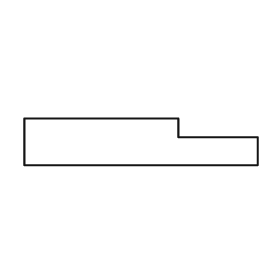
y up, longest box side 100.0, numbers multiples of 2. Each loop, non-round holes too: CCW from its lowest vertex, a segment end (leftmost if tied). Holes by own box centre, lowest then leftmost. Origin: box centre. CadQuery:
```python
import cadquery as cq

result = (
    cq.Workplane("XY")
    .moveTo(-50.0, -10.0)
    .lineTo(50.0, -10.0)
    .lineTo(50.0, 2.0)
    .lineTo(16.0, 2.0)
    .lineTo(16.0, 10.0)
    .lineTo(-50.0, 10.0)
    .close()
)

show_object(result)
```